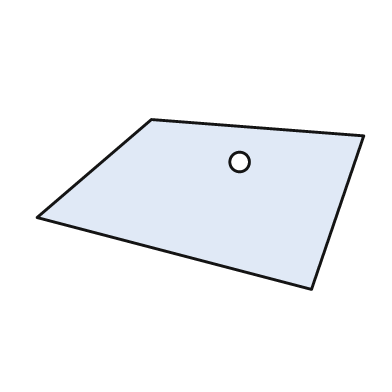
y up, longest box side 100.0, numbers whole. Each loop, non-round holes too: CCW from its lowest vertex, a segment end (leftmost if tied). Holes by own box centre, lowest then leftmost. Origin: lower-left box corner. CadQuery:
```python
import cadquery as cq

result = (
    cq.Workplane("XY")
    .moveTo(84.0, 0.0)
    .lineTo(100.0, 47.0)
    .lineTo(35.0, 52.0)
    .lineTo(0.0, 22.0)
    .close()
    .moveTo(62.0, 39.0)
    .circle(3.0)
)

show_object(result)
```